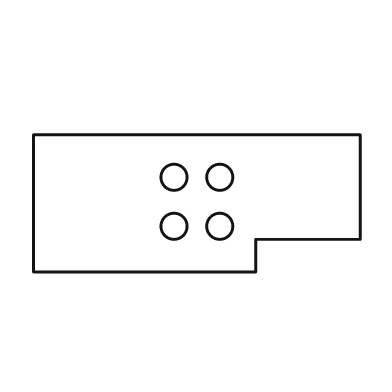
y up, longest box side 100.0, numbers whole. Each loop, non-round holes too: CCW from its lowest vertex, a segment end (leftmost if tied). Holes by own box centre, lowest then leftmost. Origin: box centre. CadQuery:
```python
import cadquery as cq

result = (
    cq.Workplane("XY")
    .moveTo(-50.0, -21.0)
    .lineTo(18.0, -21.0)
    .lineTo(18.0, -11.0)
    .lineTo(50.0, -11.0)
    .lineTo(50.0, 21.0)
    .lineTo(-50.0, 21.0)
    .close()
    .moveTo(-7.0, -7.0)
    .circle(4.0)
    .moveTo(7.0, -7.0)
    .circle(4.0)
    .moveTo(-7.0, 8.0)
    .circle(4.0)
    .moveTo(7.0, 8.0)
    .circle(4.0)
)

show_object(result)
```